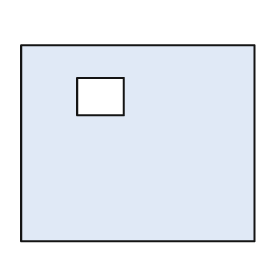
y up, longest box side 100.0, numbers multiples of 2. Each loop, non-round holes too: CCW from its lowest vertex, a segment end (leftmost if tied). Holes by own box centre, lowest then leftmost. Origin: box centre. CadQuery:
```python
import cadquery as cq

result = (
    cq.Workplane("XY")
    .moveTo(-50.0, -42.0)
    .lineTo(50.0, -42.0)
    .lineTo(50.0, 42.0)
    .lineTo(-50.0, 42.0)
    .close()
    .moveTo(-26.0, 12.0)
    .lineTo(-6.0, 12.0)
    .lineTo(-6.0, 28.0)
    .lineTo(-26.0, 28.0)
    .close()
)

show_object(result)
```